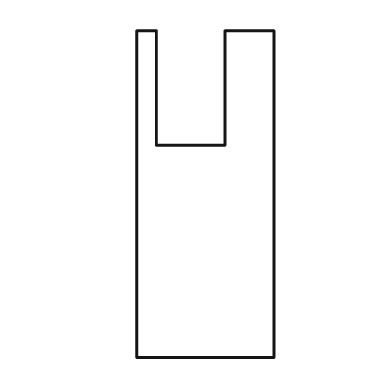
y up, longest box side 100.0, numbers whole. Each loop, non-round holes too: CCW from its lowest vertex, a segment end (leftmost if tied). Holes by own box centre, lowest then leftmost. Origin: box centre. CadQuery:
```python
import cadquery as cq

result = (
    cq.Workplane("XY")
    .moveTo(-21.0, -50.0)
    .lineTo(21.0, -50.0)
    .lineTo(21.0, 50.0)
    .lineTo(6.0, 50.0)
    .lineTo(6.0, 15.0)
    .lineTo(-15.0, 15.0)
    .lineTo(-15.0, 50.0)
    .lineTo(-21.0, 50.0)
    .close()
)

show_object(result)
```